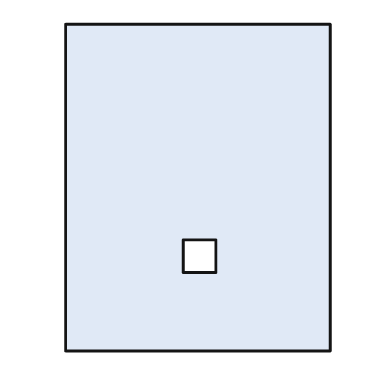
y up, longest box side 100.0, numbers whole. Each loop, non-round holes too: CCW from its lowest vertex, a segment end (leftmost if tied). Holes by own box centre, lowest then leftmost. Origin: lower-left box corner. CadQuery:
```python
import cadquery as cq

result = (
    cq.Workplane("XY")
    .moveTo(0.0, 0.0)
    .lineTo(81.0, 0.0)
    .lineTo(81.0, 100.0)
    .lineTo(0.0, 100.0)
    .close()
    .moveTo(36.0, 24.0)
    .lineTo(46.0, 24.0)
    .lineTo(46.0, 34.0)
    .lineTo(36.0, 34.0)
    .close()
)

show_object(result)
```